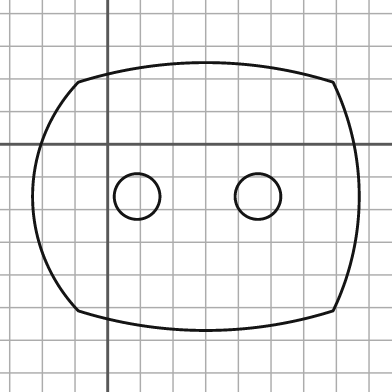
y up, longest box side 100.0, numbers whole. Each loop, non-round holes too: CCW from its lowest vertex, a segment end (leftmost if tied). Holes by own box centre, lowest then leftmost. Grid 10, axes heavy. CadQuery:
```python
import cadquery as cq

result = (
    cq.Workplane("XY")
    .moveTo(-9.0, -51.0)
    .threePointArc((30.0, -57.0), (69.0, -51.0))
    .threePointArc((77.0, -16.0), (69.0, 19.0))
    .threePointArc((30.0, 25.0), (-9.0, 19.0))
    .threePointArc((-23.0, -16.0), (-9.0, -51.0))
    .close()
    .moveTo(9.0, -16.0)
    .circle(7.0)
    .moveTo(46.0, -16.0)
    .circle(7.0)
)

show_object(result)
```